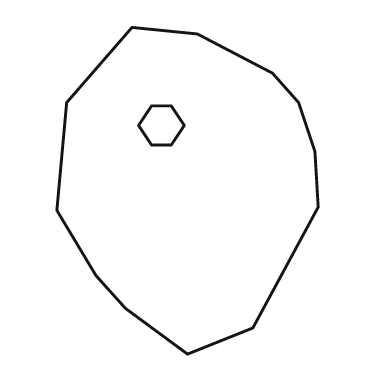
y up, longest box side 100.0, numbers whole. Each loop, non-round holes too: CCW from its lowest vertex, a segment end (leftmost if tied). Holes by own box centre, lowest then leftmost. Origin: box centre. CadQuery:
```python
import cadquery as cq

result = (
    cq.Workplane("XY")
    .moveTo(0.0, -50.0)
    .lineTo(20.0, -42.0)
    .lineTo(40.0, -5.0)
    .lineTo(39.0, 12.0)
    .lineTo(34.0, 27.0)
    .lineTo(26.0, 36.0)
    .lineTo(3.0, 48.0)
    .lineTo(-17.0, 50.0)
    .lineTo(-37.0, 27.0)
    .lineTo(-40.0, -6.0)
    .lineTo(-28.0, -26.0)
    .lineTo(-19.0, -36.0)
    .close()
    .moveTo(-11.0, 14.0)
    .lineTo(-5.0, 14.0)
    .lineTo(-1.0, 20.0)
    .lineTo(-5.0, 26.0)
    .lineTo(-11.0, 26.0)
    .lineTo(-15.0, 20.0)
    .close()
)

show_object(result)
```